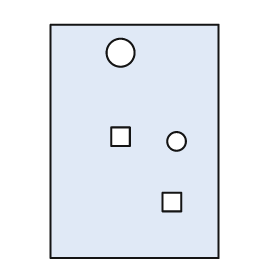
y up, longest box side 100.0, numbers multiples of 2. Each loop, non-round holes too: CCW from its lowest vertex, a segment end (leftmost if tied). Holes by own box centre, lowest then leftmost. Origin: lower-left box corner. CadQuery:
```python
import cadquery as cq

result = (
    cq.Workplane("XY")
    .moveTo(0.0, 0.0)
    .lineTo(72.0, 0.0)
    .lineTo(72.0, 100.0)
    .lineTo(0.0, 100.0)
    .close()
    .moveTo(48.0, 20.0)
    .lineTo(56.0, 20.0)
    .lineTo(56.0, 28.0)
    .lineTo(48.0, 28.0)
    .close()
    .moveTo(54.0, 50.0)
    .circle(4.0)
    .moveTo(26.0, 48.0)
    .lineTo(34.0, 48.0)
    .lineTo(34.0, 56.0)
    .lineTo(26.0, 56.0)
    .close()
    .moveTo(30.0, 88.0)
    .circle(6.0)
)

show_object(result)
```